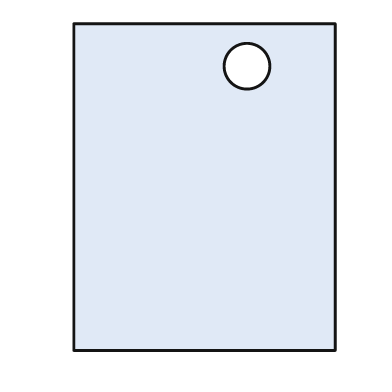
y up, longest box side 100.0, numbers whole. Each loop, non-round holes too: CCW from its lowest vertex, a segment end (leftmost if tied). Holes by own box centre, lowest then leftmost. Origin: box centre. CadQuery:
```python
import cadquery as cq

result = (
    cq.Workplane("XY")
    .moveTo(-40.0, -50.0)
    .lineTo(40.0, -50.0)
    .lineTo(40.0, 50.0)
    .lineTo(-40.0, 50.0)
    .close()
    .moveTo(13.0, 37.0)
    .circle(7.0)
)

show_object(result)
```